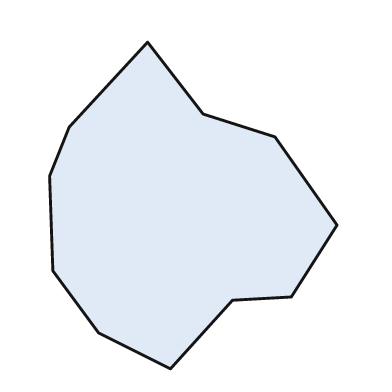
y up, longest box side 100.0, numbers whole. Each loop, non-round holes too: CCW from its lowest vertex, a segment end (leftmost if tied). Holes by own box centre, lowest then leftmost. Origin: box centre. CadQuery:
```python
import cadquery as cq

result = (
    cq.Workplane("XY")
    .moveTo(-7.0, -50.0)
    .lineTo(12.0, -29.0)
    .lineTo(30.0, -28.0)
    .lineTo(44.0, -6.0)
    .lineTo(25.0, 21.0)
    .lineTo(3.0, 28.0)
    .lineTo(-14.0, 50.0)
    .lineTo(-38.0, 24.0)
    .lineTo(-44.0, 9.0)
    .lineTo(-43.0, -20.0)
    .lineTo(-29.0, -39.0)
    .close()
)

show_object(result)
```